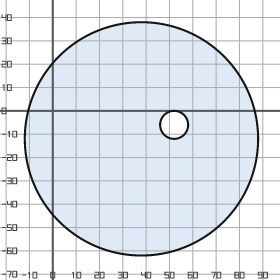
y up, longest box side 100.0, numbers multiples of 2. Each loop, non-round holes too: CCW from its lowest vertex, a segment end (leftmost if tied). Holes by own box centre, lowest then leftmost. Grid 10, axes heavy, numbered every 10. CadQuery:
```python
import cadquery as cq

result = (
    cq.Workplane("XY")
    .moveTo(38.0, -12.0)
    .circle(50.0)
    .moveTo(52.0, -6.0)
    .circle(6.0)
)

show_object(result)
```